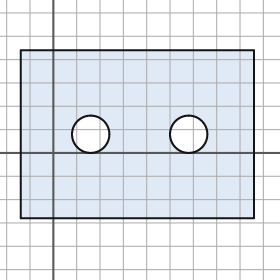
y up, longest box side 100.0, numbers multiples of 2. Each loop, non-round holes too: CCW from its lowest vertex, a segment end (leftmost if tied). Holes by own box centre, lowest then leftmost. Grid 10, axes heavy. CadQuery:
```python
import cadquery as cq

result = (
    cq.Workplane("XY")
    .moveTo(-14.0, -28.0)
    .lineTo(86.0, -28.0)
    .lineTo(86.0, 44.0)
    .lineTo(-14.0, 44.0)
    .close()
    .moveTo(16.0, 8.0)
    .circle(8.0)
    .moveTo(58.0, 8.0)
    .circle(8.0)
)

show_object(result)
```